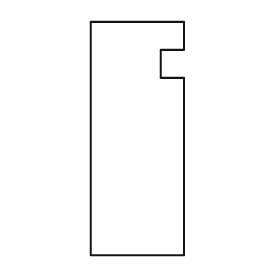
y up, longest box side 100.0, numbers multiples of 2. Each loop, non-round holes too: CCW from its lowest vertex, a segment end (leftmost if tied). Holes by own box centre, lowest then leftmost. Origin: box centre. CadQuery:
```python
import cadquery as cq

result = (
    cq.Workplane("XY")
    .moveTo(-20.0, -50.0)
    .lineTo(20.0, -50.0)
    .lineTo(20.0, 26.0)
    .lineTo(10.0, 26.0)
    .lineTo(10.0, 38.0)
    .lineTo(20.0, 38.0)
    .lineTo(20.0, 50.0)
    .lineTo(-20.0, 50.0)
    .close()
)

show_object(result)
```